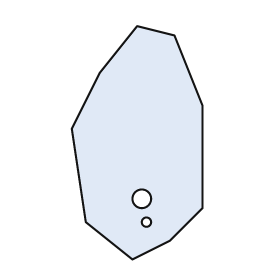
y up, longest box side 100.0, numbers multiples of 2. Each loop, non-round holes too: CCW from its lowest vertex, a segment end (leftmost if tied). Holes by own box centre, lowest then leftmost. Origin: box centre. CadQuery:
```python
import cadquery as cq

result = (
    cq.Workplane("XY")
    .moveTo(-2.0, -50.0)
    .lineTo(14.0, -42.0)
    .lineTo(28.0, -28.0)
    .lineTo(28.0, 16.0)
    .lineTo(16.0, 46.0)
    .lineTo(0.0, 50.0)
    .lineTo(-16.0, 30.0)
    .lineTo(-28.0, 6.0)
    .lineTo(-22.0, -34.0)
    .close()
    .moveTo(4.0, -34.0)
    .circle(2.0)
    .moveTo(2.0, -24.0)
    .circle(4.0)
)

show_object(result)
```